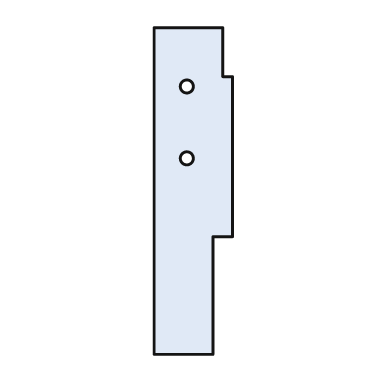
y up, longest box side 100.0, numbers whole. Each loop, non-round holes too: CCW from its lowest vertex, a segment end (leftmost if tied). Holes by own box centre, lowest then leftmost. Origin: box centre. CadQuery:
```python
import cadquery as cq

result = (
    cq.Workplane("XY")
    .moveTo(-12.0, -50.0)
    .lineTo(6.0, -50.0)
    .lineTo(6.0, -14.0)
    .lineTo(12.0, -14.0)
    .lineTo(12.0, 35.0)
    .lineTo(9.0, 35.0)
    .lineTo(9.0, 50.0)
    .lineTo(-12.0, 50.0)
    .close()
    .moveTo(-2.0, 10.0)
    .circle(2.0)
    .moveTo(-2.0, 32.0)
    .circle(2.0)
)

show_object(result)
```